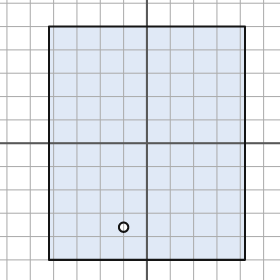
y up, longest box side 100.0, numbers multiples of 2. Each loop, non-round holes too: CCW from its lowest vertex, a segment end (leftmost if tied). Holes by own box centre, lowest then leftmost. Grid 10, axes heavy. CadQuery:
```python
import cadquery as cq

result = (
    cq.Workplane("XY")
    .moveTo(-42.0, -50.0)
    .lineTo(42.0, -50.0)
    .lineTo(42.0, 50.0)
    .lineTo(-42.0, 50.0)
    .close()
    .moveTo(-10.0, -36.0)
    .circle(2.0)
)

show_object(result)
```